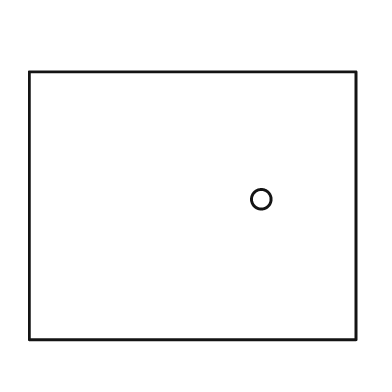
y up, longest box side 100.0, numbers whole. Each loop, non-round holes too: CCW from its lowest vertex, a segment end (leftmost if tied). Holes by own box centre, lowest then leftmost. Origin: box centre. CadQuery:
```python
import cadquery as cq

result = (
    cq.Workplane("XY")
    .moveTo(-50.0, -41.0)
    .lineTo(50.0, -41.0)
    .lineTo(50.0, 41.0)
    .lineTo(-50.0, 41.0)
    .close()
    .moveTo(21.0, 2.0)
    .circle(3.0)
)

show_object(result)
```